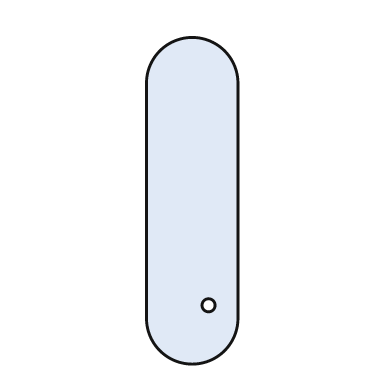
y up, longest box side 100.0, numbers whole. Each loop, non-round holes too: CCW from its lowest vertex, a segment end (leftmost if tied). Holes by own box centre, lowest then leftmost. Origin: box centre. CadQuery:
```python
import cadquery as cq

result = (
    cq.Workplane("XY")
    .moveTo(-14.0, -36.0)
    .threePointArc((0.0, -50.0), (14.0, -36.0))
    .lineTo(14.0, 36.0)
    .threePointArc((0.0, 50.0), (-14.0, 36.0))
    .close()
    .moveTo(5.0, -32.0)
    .circle(2.0)
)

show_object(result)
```